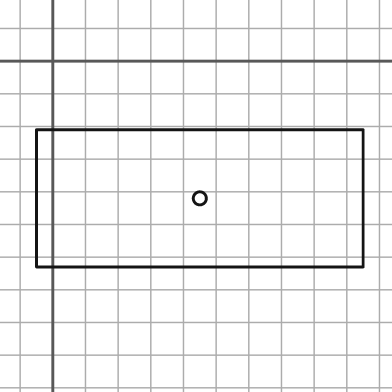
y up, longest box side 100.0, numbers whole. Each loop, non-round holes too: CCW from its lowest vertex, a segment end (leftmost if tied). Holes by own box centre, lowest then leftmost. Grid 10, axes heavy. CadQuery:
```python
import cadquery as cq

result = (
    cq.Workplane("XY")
    .moveTo(-5.0, -63.0)
    .lineTo(95.0, -63.0)
    .lineTo(95.0, -21.0)
    .lineTo(-5.0, -21.0)
    .close()
    .moveTo(45.0, -42.0)
    .circle(2.0)
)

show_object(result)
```